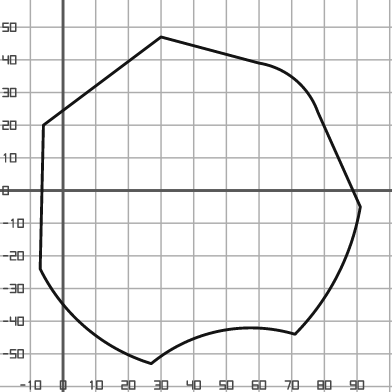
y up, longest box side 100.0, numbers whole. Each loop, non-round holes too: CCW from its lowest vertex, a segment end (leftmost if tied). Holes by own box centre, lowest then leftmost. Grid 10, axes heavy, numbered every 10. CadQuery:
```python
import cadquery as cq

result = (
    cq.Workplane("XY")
    .moveTo(27.0, -53.0)
    .threePointArc((48.0, -43.0), (71.0, -44.0))
    .threePointArc((84.0, -26.0), (91.0, -5.0))
    .lineTo(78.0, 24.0)
    .threePointArc((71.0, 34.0), (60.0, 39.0))
    .lineTo(30.0, 47.0)
    .lineTo(-6.0, 20.0)
    .lineTo(-7.0, -24.0)
    .threePointArc((7.0, -42.0), (27.0, -53.0))
    .close()
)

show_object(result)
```